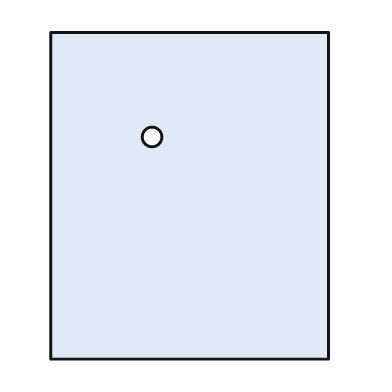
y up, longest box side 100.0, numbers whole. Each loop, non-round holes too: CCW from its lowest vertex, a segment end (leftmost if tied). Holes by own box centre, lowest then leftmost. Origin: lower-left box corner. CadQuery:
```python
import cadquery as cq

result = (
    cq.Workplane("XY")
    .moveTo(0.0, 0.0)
    .lineTo(85.0, 0.0)
    .lineTo(85.0, 100.0)
    .lineTo(0.0, 100.0)
    .close()
    .moveTo(31.0, 68.0)
    .circle(3.0)
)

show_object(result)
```